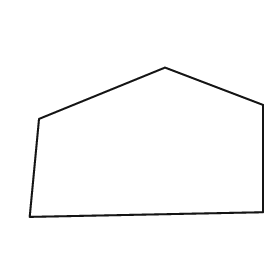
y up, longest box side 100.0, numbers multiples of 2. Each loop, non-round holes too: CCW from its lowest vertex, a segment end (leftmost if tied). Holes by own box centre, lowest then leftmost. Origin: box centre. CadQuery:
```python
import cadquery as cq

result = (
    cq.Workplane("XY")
    .moveTo(-50.0, -32.0)
    .lineTo(50.0, -30.0)
    .lineTo(50.0, 16.0)
    .lineTo(8.0, 32.0)
    .lineTo(-46.0, 10.0)
    .close()
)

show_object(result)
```